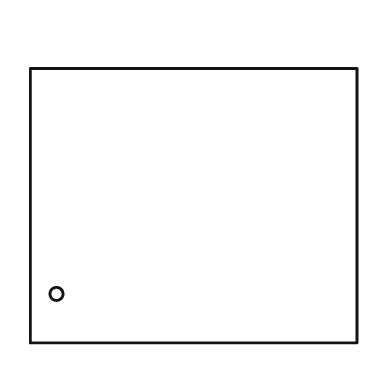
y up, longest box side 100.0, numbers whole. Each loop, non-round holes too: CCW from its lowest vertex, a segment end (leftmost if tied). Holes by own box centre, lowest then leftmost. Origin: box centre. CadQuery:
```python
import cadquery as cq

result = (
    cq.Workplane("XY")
    .moveTo(-50.0, -42.0)
    .lineTo(50.0, -42.0)
    .lineTo(50.0, 42.0)
    .lineTo(-50.0, 42.0)
    .close()
    .moveTo(-42.0, -27.0)
    .circle(2.0)
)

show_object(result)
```